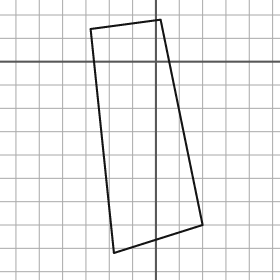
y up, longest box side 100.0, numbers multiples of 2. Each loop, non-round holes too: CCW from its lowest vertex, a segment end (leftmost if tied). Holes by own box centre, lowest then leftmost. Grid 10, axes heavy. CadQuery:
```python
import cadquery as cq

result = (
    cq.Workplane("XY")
    .moveTo(-18.0, -82.0)
    .lineTo(20.0, -70.0)
    .lineTo(2.0, 18.0)
    .lineTo(-28.0, 14.0)
    .close()
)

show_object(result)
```